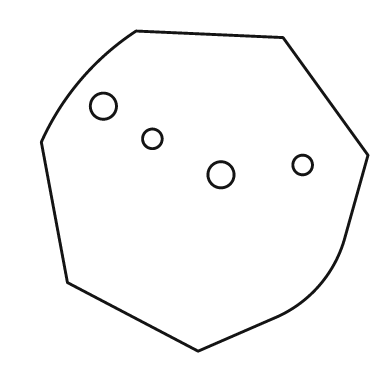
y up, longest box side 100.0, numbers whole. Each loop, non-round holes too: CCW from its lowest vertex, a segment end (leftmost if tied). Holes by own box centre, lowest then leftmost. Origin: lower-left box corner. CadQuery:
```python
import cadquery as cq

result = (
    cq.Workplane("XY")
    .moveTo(48.0, 0.0)
    .lineTo(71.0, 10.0)
    .threePointArc((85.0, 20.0), (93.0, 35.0))
    .lineTo(100.0, 60.0)
    .lineTo(74.0, 96.0)
    .lineTo(29.0, 98.0)
    .threePointArc((12.0, 83.0), (0.0, 64.0))
    .lineTo(8.0, 21.0)
    .close()
    .moveTo(55.0, 54.0)
    .circle(4.0)
    .moveTo(80.0, 57.0)
    .circle(3.0)
    .moveTo(34.0, 65.0)
    .circle(3.0)
    .moveTo(19.0, 75.0)
    .circle(4.0)
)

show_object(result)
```